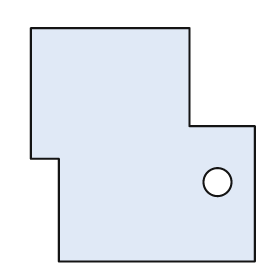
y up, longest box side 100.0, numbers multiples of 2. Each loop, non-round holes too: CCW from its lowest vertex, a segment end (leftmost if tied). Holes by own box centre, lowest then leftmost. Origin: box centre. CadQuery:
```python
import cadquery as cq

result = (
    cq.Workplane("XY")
    .moveTo(-36.0, -50.0)
    .lineTo(48.0, -50.0)
    .lineTo(48.0, 8.0)
    .lineTo(20.0, 8.0)
    .lineTo(20.0, 50.0)
    .lineTo(-48.0, 50.0)
    .lineTo(-48.0, -6.0)
    .lineTo(-36.0, -6.0)
    .close()
    .moveTo(32.0, -16.0)
    .circle(6.0)
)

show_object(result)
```